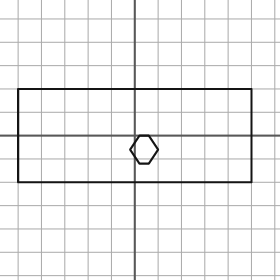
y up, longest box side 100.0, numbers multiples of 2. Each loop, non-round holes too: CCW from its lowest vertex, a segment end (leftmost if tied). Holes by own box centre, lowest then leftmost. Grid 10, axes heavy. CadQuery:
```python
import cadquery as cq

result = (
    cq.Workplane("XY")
    .moveTo(-50.0, -20.0)
    .lineTo(50.0, -20.0)
    .lineTo(50.0, 20.0)
    .lineTo(-50.0, 20.0)
    .close()
    .moveTo(2.0, -12.0)
    .lineTo(6.0, -12.0)
    .lineTo(10.0, -6.0)
    .lineTo(6.0, 0.0)
    .lineTo(2.0, 0.0)
    .lineTo(-2.0, -6.0)
    .close()
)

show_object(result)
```